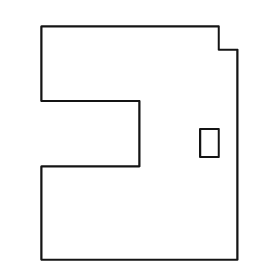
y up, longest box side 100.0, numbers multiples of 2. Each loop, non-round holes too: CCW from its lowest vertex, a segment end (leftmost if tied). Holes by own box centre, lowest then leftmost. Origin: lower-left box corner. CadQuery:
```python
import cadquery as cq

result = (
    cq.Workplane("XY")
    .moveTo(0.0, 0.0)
    .lineTo(84.0, 0.0)
    .lineTo(84.0, 90.0)
    .lineTo(76.0, 90.0)
    .lineTo(76.0, 100.0)
    .lineTo(0.0, 100.0)
    .lineTo(0.0, 68.0)
    .lineTo(42.0, 68.0)
    .lineTo(42.0, 40.0)
    .lineTo(0.0, 40.0)
    .close()
    .moveTo(68.0, 44.0)
    .lineTo(76.0, 44.0)
    .lineTo(76.0, 56.0)
    .lineTo(68.0, 56.0)
    .close()
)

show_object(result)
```